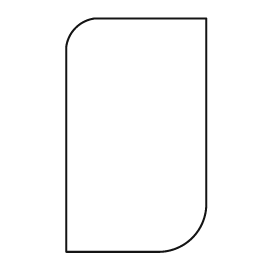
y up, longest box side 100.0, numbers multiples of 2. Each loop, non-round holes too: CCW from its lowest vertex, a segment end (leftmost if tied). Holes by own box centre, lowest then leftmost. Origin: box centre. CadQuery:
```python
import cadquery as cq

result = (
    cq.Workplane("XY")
    .moveTo(-30.0, -50.0)
    .lineTo(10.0, -50.0)
    .threePointArc((24.0, -44.0), (30.0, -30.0))
    .lineTo(30.0, 50.0)
    .lineTo(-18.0, 50.0)
    .threePointArc((-26.0, 46.0), (-30.0, 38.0))
    .close()
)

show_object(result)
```